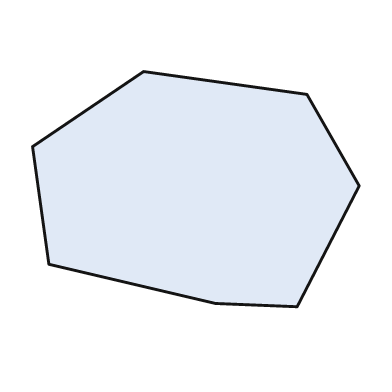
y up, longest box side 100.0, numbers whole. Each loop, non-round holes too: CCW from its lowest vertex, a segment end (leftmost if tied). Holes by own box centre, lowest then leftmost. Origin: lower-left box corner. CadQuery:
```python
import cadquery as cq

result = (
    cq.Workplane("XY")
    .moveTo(81.0, 0.0)
    .lineTo(100.0, 37.0)
    .lineTo(84.0, 65.0)
    .lineTo(34.0, 72.0)
    .lineTo(0.0, 49.0)
    .lineTo(5.0, 13.0)
    .lineTo(56.0, 1.0)
    .close()
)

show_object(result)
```